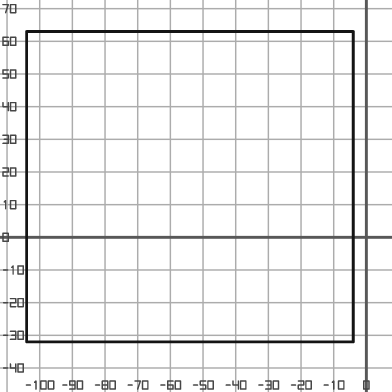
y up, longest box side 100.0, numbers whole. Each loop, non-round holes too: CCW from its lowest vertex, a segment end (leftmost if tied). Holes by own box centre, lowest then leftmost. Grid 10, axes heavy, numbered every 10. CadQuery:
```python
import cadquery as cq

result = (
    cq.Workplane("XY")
    .moveTo(-104.0, -32.0)
    .lineTo(-4.0, -32.0)
    .lineTo(-4.0, 63.0)
    .lineTo(-104.0, 63.0)
    .close()
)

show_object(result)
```